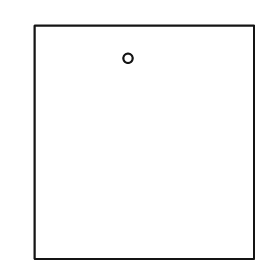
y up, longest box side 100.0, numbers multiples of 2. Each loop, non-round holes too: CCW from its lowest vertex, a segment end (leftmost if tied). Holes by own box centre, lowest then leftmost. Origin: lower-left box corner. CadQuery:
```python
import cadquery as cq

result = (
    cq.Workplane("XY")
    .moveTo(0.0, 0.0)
    .lineTo(94.0, 0.0)
    .lineTo(94.0, 100.0)
    .lineTo(0.0, 100.0)
    .close()
    .moveTo(40.0, 86.0)
    .circle(2.0)
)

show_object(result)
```